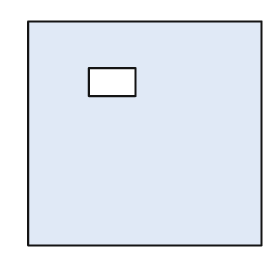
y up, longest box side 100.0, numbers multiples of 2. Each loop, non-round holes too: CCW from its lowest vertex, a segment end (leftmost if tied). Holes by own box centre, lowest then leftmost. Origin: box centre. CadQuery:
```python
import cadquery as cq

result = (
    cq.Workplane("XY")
    .moveTo(-50.0, -48.0)
    .lineTo(50.0, -48.0)
    .lineTo(50.0, 48.0)
    .lineTo(-50.0, 48.0)
    .close()
    .moveTo(-24.0, 16.0)
    .lineTo(-4.0, 16.0)
    .lineTo(-4.0, 28.0)
    .lineTo(-24.0, 28.0)
    .close()
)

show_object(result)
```